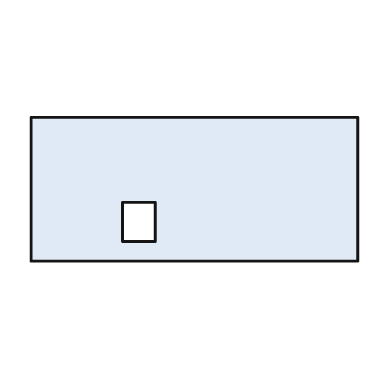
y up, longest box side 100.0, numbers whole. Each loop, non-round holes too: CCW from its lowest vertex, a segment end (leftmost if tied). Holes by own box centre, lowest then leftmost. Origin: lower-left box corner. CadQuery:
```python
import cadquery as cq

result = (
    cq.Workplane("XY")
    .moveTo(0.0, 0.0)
    .lineTo(100.0, 0.0)
    .lineTo(100.0, 44.0)
    .lineTo(0.0, 44.0)
    .close()
    .moveTo(28.0, 6.0)
    .lineTo(38.0, 6.0)
    .lineTo(38.0, 18.0)
    .lineTo(28.0, 18.0)
    .close()
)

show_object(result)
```